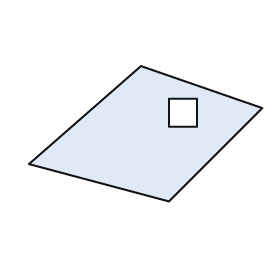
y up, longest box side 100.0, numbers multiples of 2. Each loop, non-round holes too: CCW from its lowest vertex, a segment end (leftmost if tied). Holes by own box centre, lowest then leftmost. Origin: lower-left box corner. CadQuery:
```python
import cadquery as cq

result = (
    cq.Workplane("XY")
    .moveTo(60.0, 0.0)
    .lineTo(100.0, 40.0)
    .lineTo(48.0, 58.0)
    .lineTo(0.0, 16.0)
    .close()
    .moveTo(60.0, 32.0)
    .lineTo(72.0, 32.0)
    .lineTo(72.0, 44.0)
    .lineTo(60.0, 44.0)
    .close()
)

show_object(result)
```